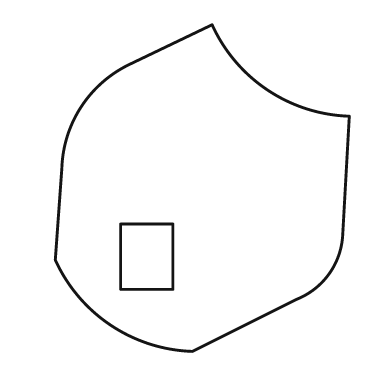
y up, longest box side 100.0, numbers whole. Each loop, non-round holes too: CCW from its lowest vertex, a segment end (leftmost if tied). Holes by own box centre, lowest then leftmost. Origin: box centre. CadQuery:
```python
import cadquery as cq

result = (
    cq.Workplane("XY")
    .moveTo(-3.0, -50.0)
    .lineTo(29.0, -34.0)
    .threePointArc((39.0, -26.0), (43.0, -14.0))
    .lineTo(45.0, 22.0)
    .threePointArc((20.0, 30.0), (3.0, 50.0))
    .lineTo(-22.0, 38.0)
    .threePointArc((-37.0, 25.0), (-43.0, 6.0))
    .lineTo(-45.0, -22.0)
    .threePointArc((-28.0, -42.0), (-3.0, -50.0))
    .close()
    .moveTo(-25.0, -31.0)
    .lineTo(-9.0, -31.0)
    .lineTo(-9.0, -11.0)
    .lineTo(-25.0, -11.0)
    .close()
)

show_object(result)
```